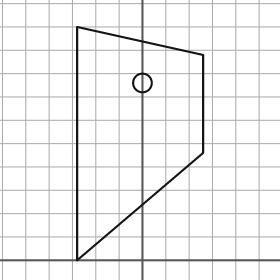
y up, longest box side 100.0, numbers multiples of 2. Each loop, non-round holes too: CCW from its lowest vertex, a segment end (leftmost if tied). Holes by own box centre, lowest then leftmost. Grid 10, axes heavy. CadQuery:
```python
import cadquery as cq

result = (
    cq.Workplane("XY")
    .moveTo(-28.0, 0.0)
    .lineTo(26.0, 46.0)
    .lineTo(26.0, 88.0)
    .lineTo(-28.0, 100.0)
    .close()
    .moveTo(0.0, 76.0)
    .circle(4.0)
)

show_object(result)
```